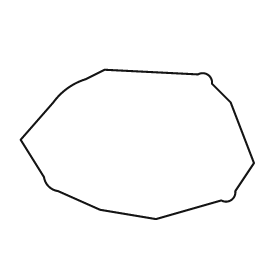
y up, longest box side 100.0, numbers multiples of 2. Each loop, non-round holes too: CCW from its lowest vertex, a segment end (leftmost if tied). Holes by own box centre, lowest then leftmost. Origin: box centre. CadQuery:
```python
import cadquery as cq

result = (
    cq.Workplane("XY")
    .moveTo(8.0, -32.0)
    .lineTo(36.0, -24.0)
    .threePointArc((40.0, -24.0), (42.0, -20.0))
    .lineTo(50.0, -8.0)
    .lineTo(40.0, 18.0)
    .lineTo(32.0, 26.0)
    .threePointArc((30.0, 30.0), (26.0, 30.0))
    .lineTo(-14.0, 32.0)
    .lineTo(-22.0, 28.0)
    .threePointArc((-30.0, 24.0), (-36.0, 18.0))
    .lineTo(-50.0, 2.0)
    .lineTo(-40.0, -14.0)
    .threePointArc((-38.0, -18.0), (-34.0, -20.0))
    .lineTo(-16.0, -28.0)
    .close()
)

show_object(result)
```